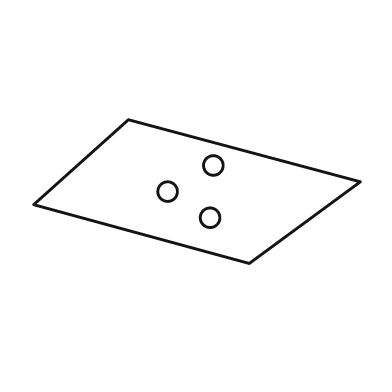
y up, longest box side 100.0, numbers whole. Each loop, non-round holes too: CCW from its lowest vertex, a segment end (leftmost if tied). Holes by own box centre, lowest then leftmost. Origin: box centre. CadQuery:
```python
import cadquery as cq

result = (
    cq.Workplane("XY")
    .moveTo(16.0, -22.0)
    .lineTo(50.0, 3.0)
    .lineTo(-21.0, 22.0)
    .lineTo(-50.0, -4.0)
    .close()
    .moveTo(4.0, -8.0)
    .circle(3.0)
    .moveTo(-9.0, 0.0)
    .circle(3.0)
    .moveTo(5.0, 8.0)
    .circle(3.0)
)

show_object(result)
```